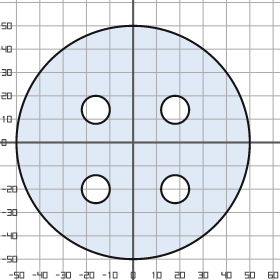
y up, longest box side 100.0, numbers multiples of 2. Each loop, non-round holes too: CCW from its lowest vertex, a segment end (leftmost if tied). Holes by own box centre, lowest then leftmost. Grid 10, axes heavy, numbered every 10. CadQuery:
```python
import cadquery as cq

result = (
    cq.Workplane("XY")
    .moveTo(0.0, 0.0)
    .circle(50.0)
    .moveTo(-16.0, -20.0)
    .circle(6.0)
    .moveTo(18.0, -20.0)
    .circle(6.0)
    .moveTo(-16.0, 14.0)
    .circle(6.0)
    .moveTo(18.0, 14.0)
    .circle(6.0)
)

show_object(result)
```